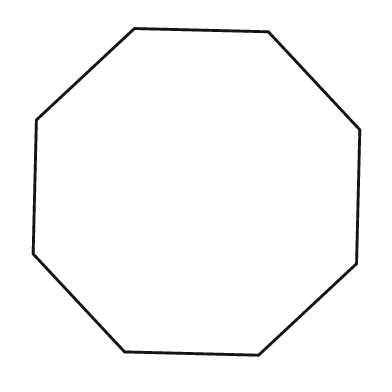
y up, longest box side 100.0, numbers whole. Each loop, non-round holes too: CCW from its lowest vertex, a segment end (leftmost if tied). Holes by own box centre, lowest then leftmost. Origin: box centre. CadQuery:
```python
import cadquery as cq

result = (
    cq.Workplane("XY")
    .moveTo(19.0, -50.0)
    .lineTo(49.0, -22.0)
    .lineTo(50.0, 19.0)
    .lineTo(22.0, 49.0)
    .lineTo(-19.0, 50.0)
    .lineTo(-49.0, 22.0)
    .lineTo(-50.0, -19.0)
    .lineTo(-22.0, -49.0)
    .close()
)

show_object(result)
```